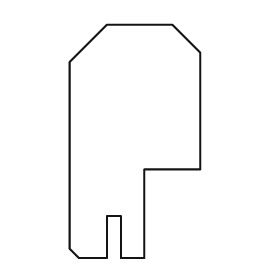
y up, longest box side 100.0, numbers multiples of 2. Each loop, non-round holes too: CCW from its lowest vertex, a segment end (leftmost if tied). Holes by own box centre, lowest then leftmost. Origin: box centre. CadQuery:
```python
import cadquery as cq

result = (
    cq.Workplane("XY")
    .moveTo(-24.0, -50.0)
    .lineTo(-12.0, -50.0)
    .lineTo(-12.0, -32.0)
    .lineTo(-6.0, -32.0)
    .lineTo(-6.0, -50.0)
    .lineTo(4.0, -50.0)
    .lineTo(4.0, -12.0)
    .lineTo(28.0, -12.0)
    .lineTo(28.0, 38.0)
    .lineTo(16.0, 50.0)
    .lineTo(-12.0, 50.0)
    .lineTo(-28.0, 34.0)
    .lineTo(-28.0, -46.0)
    .close()
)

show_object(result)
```